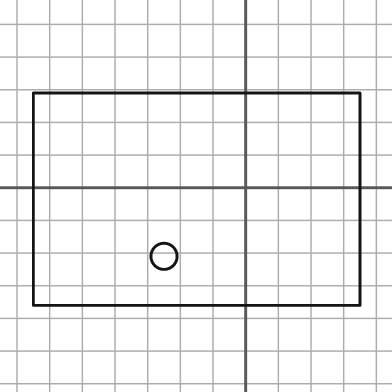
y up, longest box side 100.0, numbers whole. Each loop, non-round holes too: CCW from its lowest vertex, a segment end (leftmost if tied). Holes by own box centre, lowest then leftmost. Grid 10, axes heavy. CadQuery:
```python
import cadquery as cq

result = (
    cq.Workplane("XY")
    .moveTo(-65.0, -36.0)
    .lineTo(35.0, -36.0)
    .lineTo(35.0, 29.0)
    .lineTo(-65.0, 29.0)
    .close()
    .moveTo(-25.0, -21.0)
    .circle(4.0)
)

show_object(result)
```